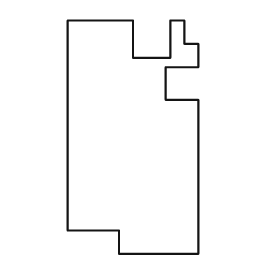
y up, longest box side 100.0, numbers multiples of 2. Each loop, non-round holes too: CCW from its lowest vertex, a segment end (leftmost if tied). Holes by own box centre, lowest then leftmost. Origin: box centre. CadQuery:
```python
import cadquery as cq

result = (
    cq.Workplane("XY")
    .moveTo(-6.0, -50.0)
    .lineTo(28.0, -50.0)
    .lineTo(28.0, 16.0)
    .lineTo(14.0, 16.0)
    .lineTo(14.0, 30.0)
    .lineTo(28.0, 30.0)
    .lineTo(28.0, 40.0)
    .lineTo(22.0, 40.0)
    .lineTo(22.0, 50.0)
    .lineTo(16.0, 50.0)
    .lineTo(16.0, 34.0)
    .lineTo(0.0, 34.0)
    .lineTo(0.0, 50.0)
    .lineTo(-28.0, 50.0)
    .lineTo(-28.0, -40.0)
    .lineTo(-6.0, -40.0)
    .close()
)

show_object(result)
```